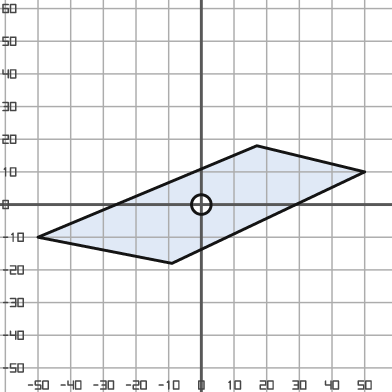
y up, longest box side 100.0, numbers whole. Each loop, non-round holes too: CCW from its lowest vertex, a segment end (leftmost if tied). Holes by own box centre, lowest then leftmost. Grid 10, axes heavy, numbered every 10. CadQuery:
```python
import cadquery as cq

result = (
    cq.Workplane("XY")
    .moveTo(-9.0, -18.0)
    .lineTo(50.0, 10.0)
    .lineTo(17.0, 18.0)
    .lineTo(-50.0, -10.0)
    .close()
    .moveTo(0.0, 0.0)
    .circle(3.0)
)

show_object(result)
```